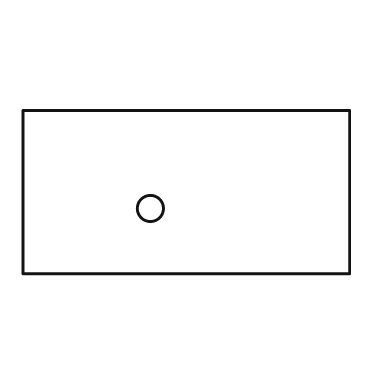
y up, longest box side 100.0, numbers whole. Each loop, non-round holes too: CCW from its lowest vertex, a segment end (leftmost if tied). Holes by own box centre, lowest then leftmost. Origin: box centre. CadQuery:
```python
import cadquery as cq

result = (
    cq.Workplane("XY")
    .moveTo(-50.0, -25.0)
    .lineTo(50.0, -25.0)
    .lineTo(50.0, 25.0)
    .lineTo(-50.0, 25.0)
    .close()
    .moveTo(-11.0, -5.0)
    .circle(4.0)
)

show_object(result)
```